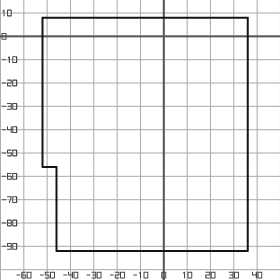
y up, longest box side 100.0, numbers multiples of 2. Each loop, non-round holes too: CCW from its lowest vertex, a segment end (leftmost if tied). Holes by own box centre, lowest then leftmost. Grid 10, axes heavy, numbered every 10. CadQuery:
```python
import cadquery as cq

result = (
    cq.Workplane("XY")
    .moveTo(-46.0, -92.0)
    .lineTo(36.0, -92.0)
    .lineTo(36.0, 8.0)
    .lineTo(-52.0, 8.0)
    .lineTo(-52.0, -56.0)
    .lineTo(-46.0, -56.0)
    .close()
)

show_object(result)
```